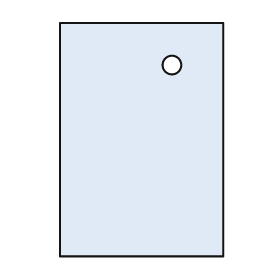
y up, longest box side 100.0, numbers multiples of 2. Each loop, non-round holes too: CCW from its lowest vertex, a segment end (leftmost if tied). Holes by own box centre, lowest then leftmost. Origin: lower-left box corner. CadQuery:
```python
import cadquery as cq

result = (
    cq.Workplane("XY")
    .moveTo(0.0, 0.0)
    .lineTo(70.0, 0.0)
    .lineTo(70.0, 100.0)
    .lineTo(0.0, 100.0)
    .close()
    .moveTo(48.0, 82.0)
    .circle(4.0)
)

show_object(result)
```